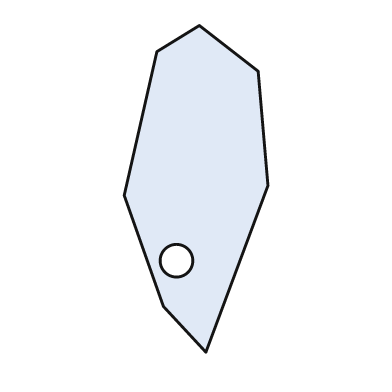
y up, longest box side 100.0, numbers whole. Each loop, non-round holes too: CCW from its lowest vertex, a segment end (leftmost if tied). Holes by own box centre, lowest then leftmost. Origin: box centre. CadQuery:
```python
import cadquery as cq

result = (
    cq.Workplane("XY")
    .moveTo(3.0, -50.0)
    .lineTo(22.0, 1.0)
    .lineTo(19.0, 36.0)
    .lineTo(1.0, 50.0)
    .lineTo(-12.0, 42.0)
    .lineTo(-22.0, -2.0)
    .lineTo(-10.0, -36.0)
    .close()
    .moveTo(-6.0, -22.0)
    .circle(5.0)
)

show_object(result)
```